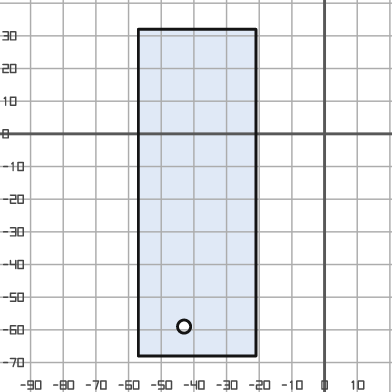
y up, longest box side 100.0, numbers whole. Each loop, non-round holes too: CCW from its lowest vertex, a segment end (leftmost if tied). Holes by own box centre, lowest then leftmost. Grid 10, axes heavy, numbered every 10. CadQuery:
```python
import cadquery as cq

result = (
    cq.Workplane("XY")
    .moveTo(-57.0, -68.0)
    .lineTo(-21.0, -68.0)
    .lineTo(-21.0, 32.0)
    .lineTo(-57.0, 32.0)
    .close()
    .moveTo(-43.0, -59.0)
    .circle(2.0)
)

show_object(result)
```